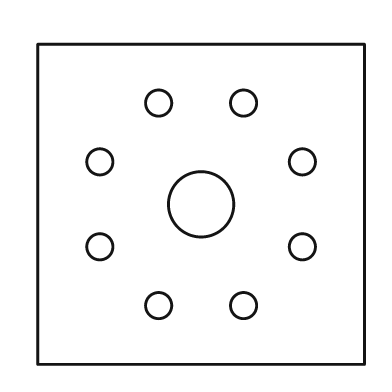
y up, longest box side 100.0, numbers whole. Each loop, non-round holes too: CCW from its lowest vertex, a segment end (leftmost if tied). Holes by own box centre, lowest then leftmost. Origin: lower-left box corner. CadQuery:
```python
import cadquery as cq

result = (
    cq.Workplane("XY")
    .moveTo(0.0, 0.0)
    .lineTo(100.0, 0.0)
    .lineTo(100.0, 98.0)
    .lineTo(0.0, 98.0)
    .close()
    .moveTo(37.0, 18.0)
    .circle(4.0)
    .moveTo(63.0, 18.0)
    .circle(4.0)
    .moveTo(19.0, 36.0)
    .circle(4.0)
    .moveTo(81.0, 36.0)
    .circle(4.0)
    .moveTo(50.0, 49.0)
    .circle(10.0)
    .moveTo(19.0, 62.0)
    .circle(4.0)
    .moveTo(81.0, 62.0)
    .circle(4.0)
    .moveTo(37.0, 80.0)
    .circle(4.0)
    .moveTo(63.0, 80.0)
    .circle(4.0)
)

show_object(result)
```